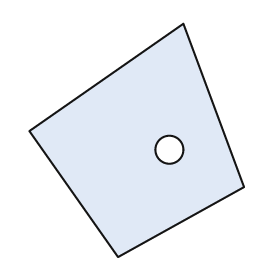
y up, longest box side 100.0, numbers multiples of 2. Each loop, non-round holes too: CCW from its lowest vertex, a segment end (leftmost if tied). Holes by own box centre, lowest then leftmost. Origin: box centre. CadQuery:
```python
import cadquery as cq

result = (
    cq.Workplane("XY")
    .moveTo(-8.0, -50.0)
    .lineTo(46.0, -20.0)
    .lineTo(20.0, 50.0)
    .lineTo(-46.0, 4.0)
    .close()
    .moveTo(14.0, -4.0)
    .circle(6.0)
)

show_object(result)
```